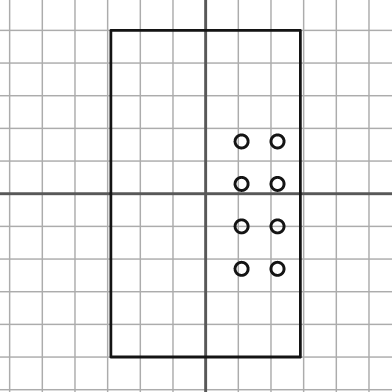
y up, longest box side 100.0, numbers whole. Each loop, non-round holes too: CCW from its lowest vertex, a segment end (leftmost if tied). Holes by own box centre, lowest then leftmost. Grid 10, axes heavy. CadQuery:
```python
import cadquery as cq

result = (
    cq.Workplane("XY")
    .moveTo(-29.0, -50.0)
    .lineTo(29.0, -50.0)
    .lineTo(29.0, 50.0)
    .lineTo(-29.0, 50.0)
    .close()
    .moveTo(11.0, -23.0)
    .circle(2.0)
    .moveTo(22.0, -23.0)
    .circle(2.0)
    .moveTo(11.0, -10.0)
    .circle(2.0)
    .moveTo(22.0, -10.0)
    .circle(2.0)
    .moveTo(11.0, 3.0)
    .circle(2.0)
    .moveTo(22.0, 3.0)
    .circle(2.0)
    .moveTo(11.0, 16.0)
    .circle(2.0)
    .moveTo(22.0, 16.0)
    .circle(2.0)
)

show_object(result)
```